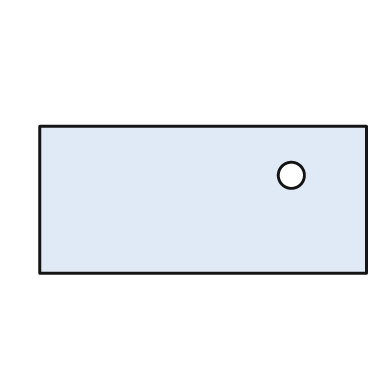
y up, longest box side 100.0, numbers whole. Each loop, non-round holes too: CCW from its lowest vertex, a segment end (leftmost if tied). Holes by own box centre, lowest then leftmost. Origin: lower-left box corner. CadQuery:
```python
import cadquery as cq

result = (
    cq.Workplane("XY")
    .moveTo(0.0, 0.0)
    .lineTo(100.0, 0.0)
    .lineTo(100.0, 45.0)
    .lineTo(0.0, 45.0)
    .close()
    .moveTo(77.0, 30.0)
    .circle(4.0)
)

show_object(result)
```